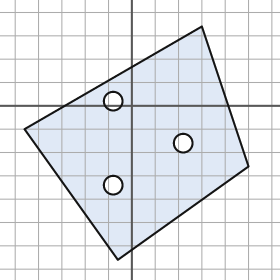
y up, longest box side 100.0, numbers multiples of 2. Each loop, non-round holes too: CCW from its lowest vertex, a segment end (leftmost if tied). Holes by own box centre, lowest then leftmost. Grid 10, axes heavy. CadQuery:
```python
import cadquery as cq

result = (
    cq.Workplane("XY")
    .moveTo(-6.0, -66.0)
    .lineTo(50.0, -26.0)
    .lineTo(30.0, 34.0)
    .lineTo(-46.0, -10.0)
    .close()
    .moveTo(-8.0, -34.0)
    .circle(4.0)
    .moveTo(22.0, -16.0)
    .circle(4.0)
    .moveTo(-8.0, 2.0)
    .circle(4.0)
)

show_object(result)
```